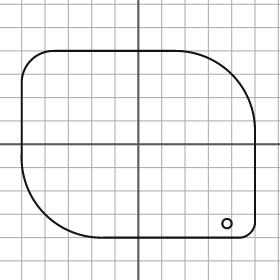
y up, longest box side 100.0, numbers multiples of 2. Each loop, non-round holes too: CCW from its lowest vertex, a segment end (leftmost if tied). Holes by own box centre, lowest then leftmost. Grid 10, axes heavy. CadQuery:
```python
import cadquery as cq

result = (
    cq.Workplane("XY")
    .moveTo(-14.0, -40.0)
    .lineTo(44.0, -40.0)
    .threePointArc((48.0, -38.0), (50.0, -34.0))
    .lineTo(50.0, 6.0)
    .threePointArc((40.0, 30.0), (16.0, 40.0))
    .lineTo(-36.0, 40.0)
    .threePointArc((-46.0, 36.0), (-50.0, 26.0))
    .lineTo(-50.0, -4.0)
    .threePointArc((-40.0, -30.0), (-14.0, -40.0))
    .close()
    .moveTo(38.0, -34.0)
    .circle(2.0)
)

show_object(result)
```